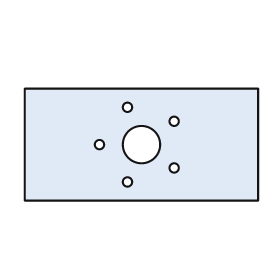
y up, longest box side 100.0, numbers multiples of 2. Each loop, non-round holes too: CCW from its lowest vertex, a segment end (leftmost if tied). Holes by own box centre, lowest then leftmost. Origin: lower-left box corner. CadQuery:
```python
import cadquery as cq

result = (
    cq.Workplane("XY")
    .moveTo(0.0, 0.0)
    .lineTo(100.0, 0.0)
    .lineTo(100.0, 48.0)
    .lineTo(0.0, 48.0)
    .close()
    .moveTo(44.0, 8.0)
    .circle(2.0)
    .moveTo(64.0, 14.0)
    .circle(2.0)
    .moveTo(32.0, 24.0)
    .circle(2.0)
    .moveTo(50.0, 24.0)
    .circle(8.0)
    .moveTo(64.0, 34.0)
    .circle(2.0)
    .moveTo(44.0, 40.0)
    .circle(2.0)
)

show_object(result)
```